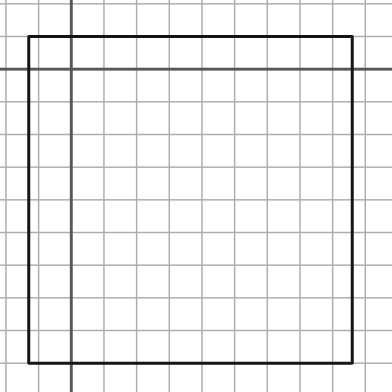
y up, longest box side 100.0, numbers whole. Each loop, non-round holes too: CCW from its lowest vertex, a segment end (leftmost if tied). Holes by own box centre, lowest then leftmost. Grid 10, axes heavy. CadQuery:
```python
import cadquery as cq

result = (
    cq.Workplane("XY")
    .moveTo(-13.0, -90.0)
    .lineTo(86.0, -90.0)
    .lineTo(86.0, 10.0)
    .lineTo(-13.0, 10.0)
    .close()
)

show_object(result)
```